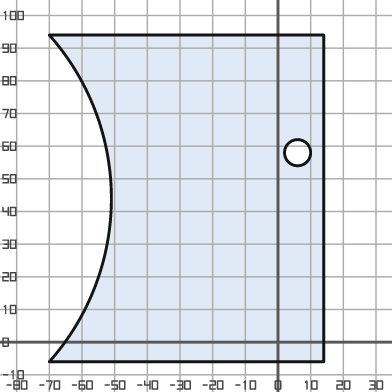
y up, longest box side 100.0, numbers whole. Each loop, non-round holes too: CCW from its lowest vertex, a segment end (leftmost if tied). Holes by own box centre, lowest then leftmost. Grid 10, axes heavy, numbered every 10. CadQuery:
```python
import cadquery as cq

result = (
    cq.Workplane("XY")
    .moveTo(-70.0, -6.0)
    .lineTo(14.0, -6.0)
    .lineTo(14.0, 94.0)
    .lineTo(-70.0, 94.0)
    .threePointArc((-51.0, 44.0), (-70.0, -6.0))
    .close()
    .moveTo(6.0, 58.0)
    .circle(4.0)
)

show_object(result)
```